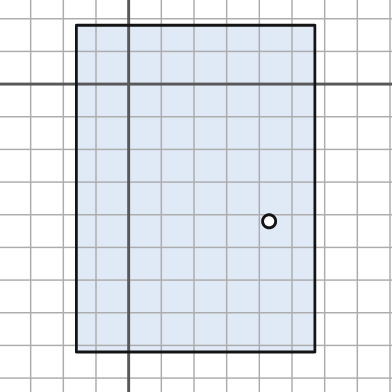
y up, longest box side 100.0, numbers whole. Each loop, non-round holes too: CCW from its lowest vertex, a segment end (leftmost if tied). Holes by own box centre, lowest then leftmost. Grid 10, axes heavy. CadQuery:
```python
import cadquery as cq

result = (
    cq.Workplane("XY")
    .moveTo(-16.0, -82.0)
    .lineTo(57.0, -82.0)
    .lineTo(57.0, 18.0)
    .lineTo(-16.0, 18.0)
    .close()
    .moveTo(43.0, -42.0)
    .circle(2.0)
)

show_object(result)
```